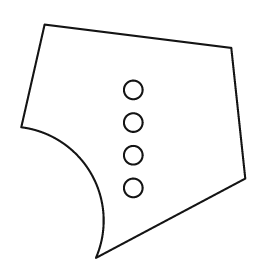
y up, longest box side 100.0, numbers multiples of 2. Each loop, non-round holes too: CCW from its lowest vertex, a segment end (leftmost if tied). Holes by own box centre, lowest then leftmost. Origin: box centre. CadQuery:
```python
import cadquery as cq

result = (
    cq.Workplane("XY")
    .moveTo(-16.0, -50.0)
    .lineTo(48.0, -16.0)
    .lineTo(42.0, 40.0)
    .lineTo(-38.0, 50.0)
    .lineTo(-48.0, 6.0)
    .threePointArc((-18.0, -14.0), (-16.0, -50.0))
    .close()
    .moveTo(0.0, -20.0)
    .circle(4.0)
    .moveTo(0.0, -6.0)
    .circle(4.0)
    .moveTo(0.0, 8.0)
    .circle(4.0)
    .moveTo(0.0, 22.0)
    .circle(4.0)
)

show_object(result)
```